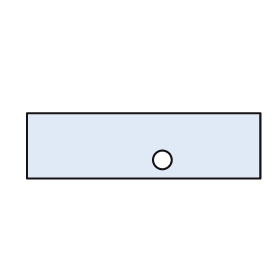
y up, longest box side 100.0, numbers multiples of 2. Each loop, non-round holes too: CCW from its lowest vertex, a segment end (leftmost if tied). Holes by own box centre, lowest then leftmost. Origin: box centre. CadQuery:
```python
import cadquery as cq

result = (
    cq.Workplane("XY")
    .moveTo(-50.0, -14.0)
    .lineTo(50.0, -14.0)
    .lineTo(50.0, 14.0)
    .lineTo(-50.0, 14.0)
    .close()
    .moveTo(8.0, -6.0)
    .circle(4.0)
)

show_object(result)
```